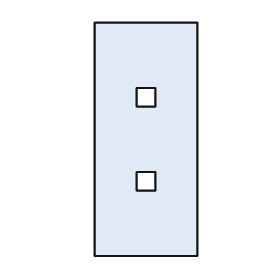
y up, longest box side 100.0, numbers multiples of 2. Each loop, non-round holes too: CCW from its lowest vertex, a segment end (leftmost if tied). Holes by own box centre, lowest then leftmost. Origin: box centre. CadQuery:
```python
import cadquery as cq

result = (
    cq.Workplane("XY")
    .moveTo(-22.0, -50.0)
    .lineTo(22.0, -50.0)
    .lineTo(22.0, 50.0)
    .lineTo(-22.0, 50.0)
    .close()
    .moveTo(-4.0, -22.0)
    .lineTo(4.0, -22.0)
    .lineTo(4.0, -14.0)
    .lineTo(-4.0, -14.0)
    .close()
    .moveTo(-4.0, 14.0)
    .lineTo(4.0, 14.0)
    .lineTo(4.0, 22.0)
    .lineTo(-4.0, 22.0)
    .close()
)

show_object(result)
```